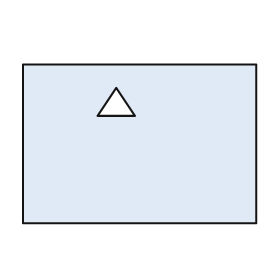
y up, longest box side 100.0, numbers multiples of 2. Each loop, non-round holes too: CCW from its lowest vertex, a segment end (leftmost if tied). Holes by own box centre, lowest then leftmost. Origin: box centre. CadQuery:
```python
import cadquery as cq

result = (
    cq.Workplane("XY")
    .moveTo(-50.0, -34.0)
    .lineTo(50.0, -34.0)
    .lineTo(50.0, 34.0)
    .lineTo(-50.0, 34.0)
    .close()
    .moveTo(-18.0, 12.0)
    .lineTo(-2.0, 12.0)
    .lineTo(-10.0, 24.0)
    .close()
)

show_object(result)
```